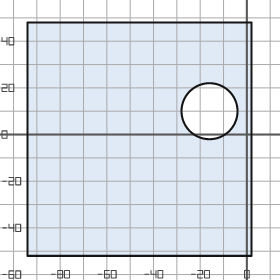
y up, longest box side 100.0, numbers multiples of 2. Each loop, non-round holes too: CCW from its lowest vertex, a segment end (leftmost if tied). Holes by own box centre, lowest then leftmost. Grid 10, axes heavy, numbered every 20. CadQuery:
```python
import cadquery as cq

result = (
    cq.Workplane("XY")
    .moveTo(-94.0, -52.0)
    .lineTo(2.0, -52.0)
    .lineTo(2.0, 48.0)
    .lineTo(-94.0, 48.0)
    .close()
    .moveTo(-16.0, 10.0)
    .circle(12.0)
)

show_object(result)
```